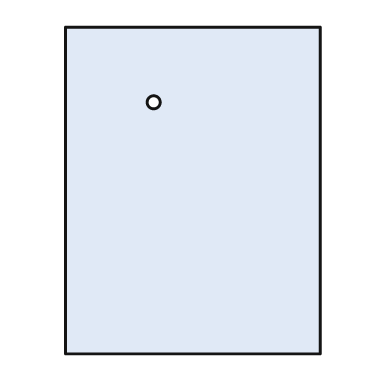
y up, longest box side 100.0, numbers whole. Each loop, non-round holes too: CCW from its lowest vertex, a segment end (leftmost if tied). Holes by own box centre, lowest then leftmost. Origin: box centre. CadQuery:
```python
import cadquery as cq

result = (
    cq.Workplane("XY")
    .moveTo(-39.0, -50.0)
    .lineTo(39.0, -50.0)
    .lineTo(39.0, 50.0)
    .lineTo(-39.0, 50.0)
    .close()
    .moveTo(-12.0, 27.0)
    .circle(2.0)
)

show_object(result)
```